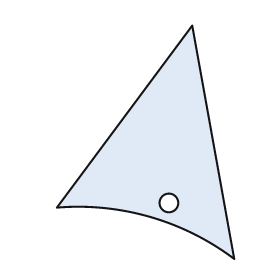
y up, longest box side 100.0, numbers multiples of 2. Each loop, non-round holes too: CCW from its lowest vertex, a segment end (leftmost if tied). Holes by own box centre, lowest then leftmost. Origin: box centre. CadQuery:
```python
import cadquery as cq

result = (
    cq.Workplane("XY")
    .moveTo(38.0, -50.0)
    .lineTo(20.0, 50.0)
    .lineTo(-38.0, -28.0)
    .threePointArc((2.0, -32.0), (38.0, -50.0))
    .close()
    .moveTo(10.0, -26.0)
    .circle(4.0)
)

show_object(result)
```